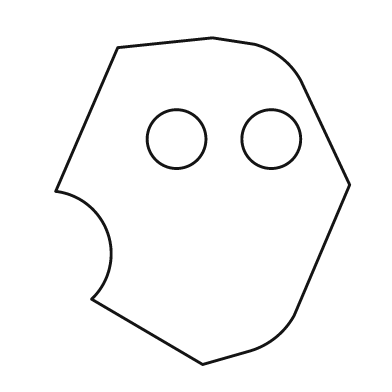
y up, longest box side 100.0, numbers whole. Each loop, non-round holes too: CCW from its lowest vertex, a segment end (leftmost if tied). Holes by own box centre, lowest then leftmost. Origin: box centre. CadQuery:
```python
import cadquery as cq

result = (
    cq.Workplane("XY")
    .moveTo(0.0, -50.0)
    .lineTo(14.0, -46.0)
    .threePointArc((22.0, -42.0), (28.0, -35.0))
    .lineTo(45.0, 5.0)
    .lineTo(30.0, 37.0)
    .threePointArc((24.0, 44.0), (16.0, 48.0))
    .lineTo(3.0, 50.0)
    .lineTo(-26.0, 47.0)
    .lineTo(-45.0, 3.0)
    .threePointArc((-29.0, -10.0), (-34.0, -30.0))
    .close()
    .moveTo(-8.0, 19.0)
    .circle(9.0)
    .moveTo(21.0, 19.0)
    .circle(9.0)
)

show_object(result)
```